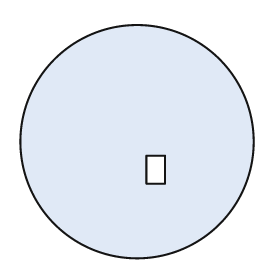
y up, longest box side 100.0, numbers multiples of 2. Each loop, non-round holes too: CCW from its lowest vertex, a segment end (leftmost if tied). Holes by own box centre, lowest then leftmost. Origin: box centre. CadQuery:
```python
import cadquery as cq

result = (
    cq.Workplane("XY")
    .moveTo(0.0, 0.0)
    .circle(50.0)
    .moveTo(4.0, -18.0)
    .lineTo(12.0, -18.0)
    .lineTo(12.0, -6.0)
    .lineTo(4.0, -6.0)
    .close()
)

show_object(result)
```